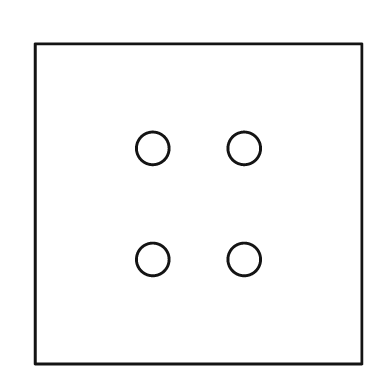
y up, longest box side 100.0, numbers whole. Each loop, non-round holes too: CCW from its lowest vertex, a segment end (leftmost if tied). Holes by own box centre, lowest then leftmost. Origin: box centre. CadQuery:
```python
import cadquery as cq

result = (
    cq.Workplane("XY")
    .moveTo(-50.0, -49.0)
    .lineTo(50.0, -49.0)
    .lineTo(50.0, 49.0)
    .lineTo(-50.0, 49.0)
    .close()
    .moveTo(-14.0, -17.0)
    .circle(5.0)
    .moveTo(14.0, -17.0)
    .circle(5.0)
    .moveTo(-14.0, 17.0)
    .circle(5.0)
    .moveTo(14.0, 17.0)
    .circle(5.0)
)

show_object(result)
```